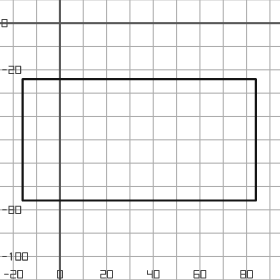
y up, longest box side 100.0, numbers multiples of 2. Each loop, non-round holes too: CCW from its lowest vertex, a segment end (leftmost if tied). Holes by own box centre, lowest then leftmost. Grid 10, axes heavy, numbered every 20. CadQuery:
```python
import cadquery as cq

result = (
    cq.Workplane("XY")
    .moveTo(-16.0, -76.0)
    .lineTo(84.0, -76.0)
    .lineTo(84.0, -24.0)
    .lineTo(-16.0, -24.0)
    .close()
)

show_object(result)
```